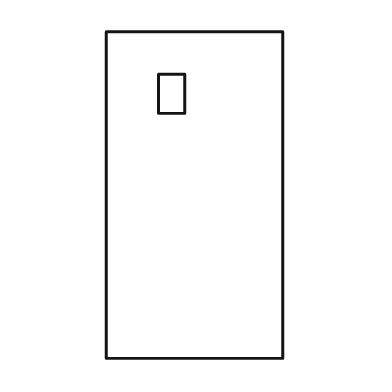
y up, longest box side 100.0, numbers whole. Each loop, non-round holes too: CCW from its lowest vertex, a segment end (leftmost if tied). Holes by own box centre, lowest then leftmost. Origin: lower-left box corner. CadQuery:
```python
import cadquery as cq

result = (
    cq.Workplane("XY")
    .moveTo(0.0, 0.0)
    .lineTo(54.0, 0.0)
    .lineTo(54.0, 100.0)
    .lineTo(0.0, 100.0)
    .close()
    .moveTo(16.0, 75.0)
    .lineTo(24.0, 75.0)
    .lineTo(24.0, 87.0)
    .lineTo(16.0, 87.0)
    .close()
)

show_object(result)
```